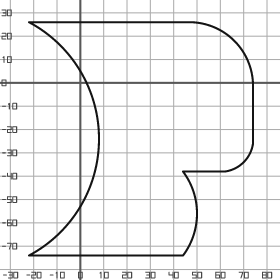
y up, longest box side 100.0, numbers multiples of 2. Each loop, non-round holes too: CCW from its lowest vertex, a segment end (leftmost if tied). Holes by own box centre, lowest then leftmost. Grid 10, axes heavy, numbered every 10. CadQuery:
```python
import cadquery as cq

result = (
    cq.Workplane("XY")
    .moveTo(-22.0, -74.0)
    .lineTo(44.0, -74.0)
    .threePointArc((50.0, -56.0), (44.0, -38.0))
    .lineTo(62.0, -38.0)
    .threePointArc((70.0, -34.0), (74.0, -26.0))
    .lineTo(74.0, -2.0)
    .threePointArc((66.0, 18.0), (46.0, 26.0))
    .lineTo(-22.0, 26.0)
    .threePointArc((8.0, -24.0), (-22.0, -74.0))
    .close()
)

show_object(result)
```